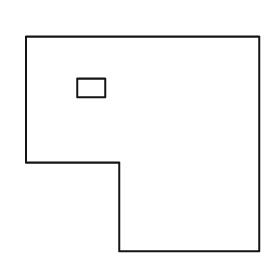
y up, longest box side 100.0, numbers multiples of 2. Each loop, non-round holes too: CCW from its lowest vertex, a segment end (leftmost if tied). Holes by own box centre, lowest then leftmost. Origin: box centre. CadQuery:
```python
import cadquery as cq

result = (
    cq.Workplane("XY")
    .moveTo(-10.0, -46.0)
    .lineTo(50.0, -46.0)
    .lineTo(50.0, 46.0)
    .lineTo(-50.0, 46.0)
    .lineTo(-50.0, -8.0)
    .lineTo(-10.0, -8.0)
    .close()
    .moveTo(-28.0, 20.0)
    .lineTo(-16.0, 20.0)
    .lineTo(-16.0, 28.0)
    .lineTo(-28.0, 28.0)
    .close()
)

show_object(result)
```